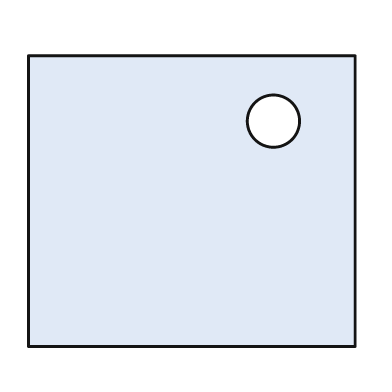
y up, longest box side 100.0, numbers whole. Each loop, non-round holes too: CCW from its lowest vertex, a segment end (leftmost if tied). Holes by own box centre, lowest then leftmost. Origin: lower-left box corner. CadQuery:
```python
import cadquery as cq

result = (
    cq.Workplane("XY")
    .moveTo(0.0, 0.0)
    .lineTo(100.0, 0.0)
    .lineTo(100.0, 89.0)
    .lineTo(0.0, 89.0)
    .close()
    .moveTo(75.0, 69.0)
    .circle(8.0)
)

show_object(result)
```